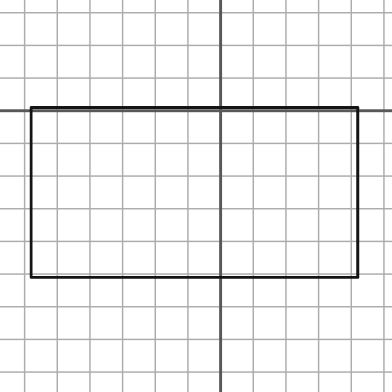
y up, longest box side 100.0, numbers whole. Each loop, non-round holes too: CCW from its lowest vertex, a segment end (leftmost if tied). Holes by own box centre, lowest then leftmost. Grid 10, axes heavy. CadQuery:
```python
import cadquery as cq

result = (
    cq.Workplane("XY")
    .moveTo(-58.0, -51.0)
    .lineTo(42.0, -51.0)
    .lineTo(42.0, 1.0)
    .lineTo(-58.0, 1.0)
    .close()
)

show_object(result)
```